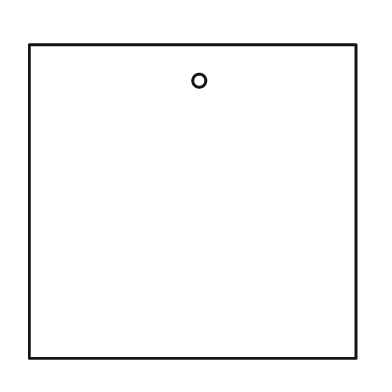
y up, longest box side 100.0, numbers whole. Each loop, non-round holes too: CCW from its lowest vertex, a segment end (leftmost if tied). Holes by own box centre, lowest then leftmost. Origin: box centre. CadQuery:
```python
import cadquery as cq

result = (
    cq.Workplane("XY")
    .moveTo(-50.0, -48.0)
    .lineTo(50.0, -48.0)
    .lineTo(50.0, 48.0)
    .lineTo(-50.0, 48.0)
    .close()
    .moveTo(2.0, 37.0)
    .circle(2.0)
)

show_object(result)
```